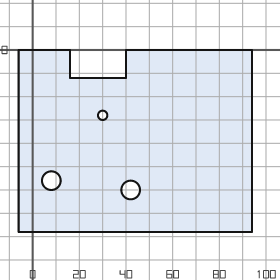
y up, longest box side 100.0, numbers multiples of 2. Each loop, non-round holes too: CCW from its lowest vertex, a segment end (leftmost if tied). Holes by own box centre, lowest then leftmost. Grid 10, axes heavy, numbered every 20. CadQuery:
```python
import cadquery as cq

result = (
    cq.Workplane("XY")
    .moveTo(-6.0, -78.0)
    .lineTo(94.0, -78.0)
    .lineTo(94.0, 0.0)
    .lineTo(40.0, 0.0)
    .lineTo(40.0, -12.0)
    .lineTo(16.0, -12.0)
    .lineTo(16.0, 0.0)
    .lineTo(-6.0, 0.0)
    .close()
    .moveTo(42.0, -60.0)
    .circle(4.0)
    .moveTo(8.0, -56.0)
    .circle(4.0)
    .moveTo(30.0, -28.0)
    .circle(2.0)
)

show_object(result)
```